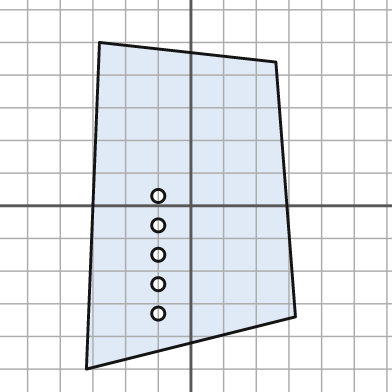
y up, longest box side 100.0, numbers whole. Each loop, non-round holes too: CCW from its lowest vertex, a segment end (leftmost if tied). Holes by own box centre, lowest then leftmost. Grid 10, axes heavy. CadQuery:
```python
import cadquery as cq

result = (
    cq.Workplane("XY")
    .moveTo(-32.0, -50.0)
    .lineTo(32.0, -34.0)
    .lineTo(26.0, 44.0)
    .lineTo(-28.0, 50.0)
    .close()
    .moveTo(-10.0, -33.0)
    .circle(2.0)
    .moveTo(-10.0, -24.0)
    .circle(2.0)
    .moveTo(-10.0, -15.0)
    .circle(2.0)
    .moveTo(-10.0, -6.0)
    .circle(2.0)
    .moveTo(-10.0, 3.0)
    .circle(2.0)
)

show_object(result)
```